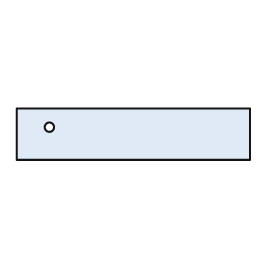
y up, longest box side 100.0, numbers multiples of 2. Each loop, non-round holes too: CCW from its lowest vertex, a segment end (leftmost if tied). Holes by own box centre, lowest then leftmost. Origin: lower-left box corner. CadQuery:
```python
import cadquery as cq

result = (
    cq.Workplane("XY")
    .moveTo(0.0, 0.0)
    .lineTo(100.0, 0.0)
    .lineTo(100.0, 22.0)
    .lineTo(0.0, 22.0)
    .close()
    .moveTo(14.0, 14.0)
    .circle(2.0)
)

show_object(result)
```